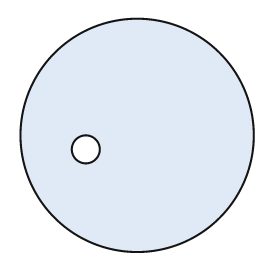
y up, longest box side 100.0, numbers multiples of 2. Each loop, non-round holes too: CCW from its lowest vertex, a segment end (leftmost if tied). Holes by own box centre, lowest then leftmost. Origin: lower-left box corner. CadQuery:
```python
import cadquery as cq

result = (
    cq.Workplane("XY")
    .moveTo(50.0, 50.0)
    .circle(50.0)
    .moveTo(28.0, 44.0)
    .circle(6.0)
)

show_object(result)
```